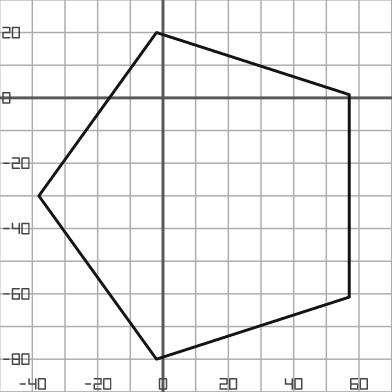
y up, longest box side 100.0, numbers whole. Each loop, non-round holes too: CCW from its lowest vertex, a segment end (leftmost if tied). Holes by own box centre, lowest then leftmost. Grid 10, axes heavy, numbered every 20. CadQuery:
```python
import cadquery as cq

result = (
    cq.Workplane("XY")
    .moveTo(-2.0, -80.0)
    .lineTo(57.0, -61.0)
    .lineTo(57.0, 1.0)
    .lineTo(-2.0, 20.0)
    .lineTo(-38.0, -30.0)
    .close()
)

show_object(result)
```